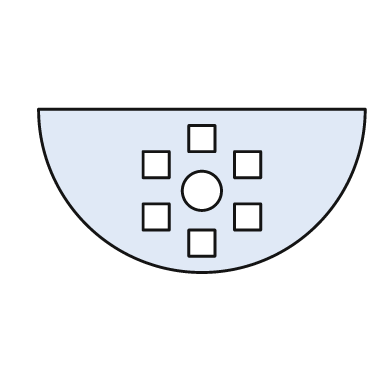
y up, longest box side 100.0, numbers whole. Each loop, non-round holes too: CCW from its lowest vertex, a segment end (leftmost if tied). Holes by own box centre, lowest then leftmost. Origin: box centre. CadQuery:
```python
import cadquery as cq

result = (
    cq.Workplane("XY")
    .moveTo(-50.0, 25.0)
    .threePointArc((0.0, -25.0), (50.0, 25.0))
    .close()
    .moveTo(-4.0, -20.0)
    .lineTo(4.0, -20.0)
    .lineTo(4.0, -12.0)
    .lineTo(-4.0, -12.0)
    .close()
    .moveTo(-18.0, -12.0)
    .lineTo(-10.0, -12.0)
    .lineTo(-10.0, -4.0)
    .lineTo(-18.0, -4.0)
    .close()
    .moveTo(10.0, -12.0)
    .lineTo(18.0, -12.0)
    .lineTo(18.0, -4.0)
    .lineTo(10.0, -4.0)
    .close()
    .moveTo(0.0, 0.0)
    .circle(6.0)
    .moveTo(-18.0, 4.0)
    .lineTo(-10.0, 4.0)
    .lineTo(-10.0, 12.0)
    .lineTo(-18.0, 12.0)
    .close()
    .moveTo(10.0, 4.0)
    .lineTo(18.0, 4.0)
    .lineTo(18.0, 12.0)
    .lineTo(10.0, 12.0)
    .close()
    .moveTo(-4.0, 12.0)
    .lineTo(4.0, 12.0)
    .lineTo(4.0, 20.0)
    .lineTo(-4.0, 20.0)
    .close()
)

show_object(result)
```